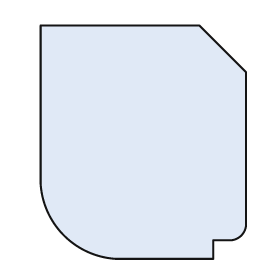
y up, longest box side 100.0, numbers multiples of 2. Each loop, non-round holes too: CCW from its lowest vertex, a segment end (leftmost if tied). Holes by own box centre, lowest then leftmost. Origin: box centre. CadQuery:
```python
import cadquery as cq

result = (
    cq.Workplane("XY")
    .moveTo(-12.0, -50.0)
    .lineTo(30.0, -50.0)
    .lineTo(30.0, -42.0)
    .lineTo(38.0, -42.0)
    .threePointArc((42.0, -40.0), (44.0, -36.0))
    .lineTo(44.0, 30.0)
    .lineTo(24.0, 50.0)
    .lineTo(-44.0, 50.0)
    .lineTo(-44.0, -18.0)
    .threePointArc((-34.0, -40.0), (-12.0, -50.0))
    .close()
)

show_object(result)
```